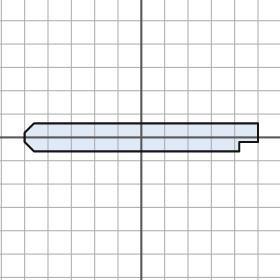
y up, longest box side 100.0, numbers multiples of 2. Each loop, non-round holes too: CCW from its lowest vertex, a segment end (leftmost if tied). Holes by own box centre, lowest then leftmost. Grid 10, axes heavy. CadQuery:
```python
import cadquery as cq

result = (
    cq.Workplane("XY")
    .moveTo(-46.0, -6.0)
    .lineTo(42.0, -6.0)
    .lineTo(42.0, -2.0)
    .lineTo(50.0, -2.0)
    .lineTo(50.0, 6.0)
    .lineTo(-46.0, 6.0)
    .lineTo(-50.0, 2.0)
    .lineTo(-50.0, -2.0)
    .close()
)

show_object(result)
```